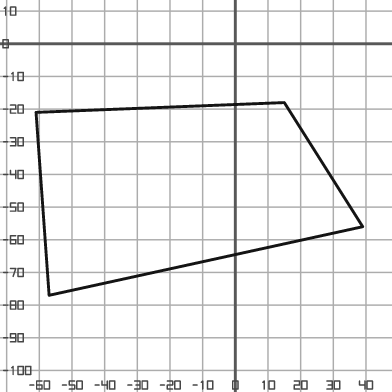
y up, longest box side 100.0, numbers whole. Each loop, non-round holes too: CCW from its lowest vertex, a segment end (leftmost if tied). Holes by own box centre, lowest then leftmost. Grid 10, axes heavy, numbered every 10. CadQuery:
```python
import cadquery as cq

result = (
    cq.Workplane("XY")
    .moveTo(-57.0, -77.0)
    .lineTo(39.0, -56.0)
    .lineTo(15.0, -18.0)
    .lineTo(-61.0, -21.0)
    .close()
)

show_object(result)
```